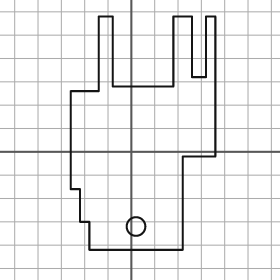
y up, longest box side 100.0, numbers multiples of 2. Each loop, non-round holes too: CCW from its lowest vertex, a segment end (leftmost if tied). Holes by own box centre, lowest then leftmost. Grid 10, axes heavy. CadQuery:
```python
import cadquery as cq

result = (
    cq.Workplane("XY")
    .moveTo(-18.0, -42.0)
    .lineTo(22.0, -42.0)
    .lineTo(22.0, -2.0)
    .lineTo(36.0, -2.0)
    .lineTo(36.0, 58.0)
    .lineTo(32.0, 58.0)
    .lineTo(32.0, 32.0)
    .lineTo(26.0, 32.0)
    .lineTo(26.0, 58.0)
    .lineTo(18.0, 58.0)
    .lineTo(18.0, 28.0)
    .lineTo(-8.0, 28.0)
    .lineTo(-8.0, 58.0)
    .lineTo(-14.0, 58.0)
    .lineTo(-14.0, 26.0)
    .lineTo(-26.0, 26.0)
    .lineTo(-26.0, -16.0)
    .lineTo(-22.0, -16.0)
    .lineTo(-22.0, -30.0)
    .lineTo(-18.0, -30.0)
    .close()
    .moveTo(2.0, -32.0)
    .circle(4.0)
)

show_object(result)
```